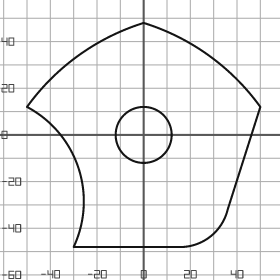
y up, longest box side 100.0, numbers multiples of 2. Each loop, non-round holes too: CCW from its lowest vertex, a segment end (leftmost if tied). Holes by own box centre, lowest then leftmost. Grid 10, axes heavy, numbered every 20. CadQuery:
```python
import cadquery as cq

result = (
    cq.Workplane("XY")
    .moveTo(-30.0, -48.0)
    .lineTo(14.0, -48.0)
    .threePointArc((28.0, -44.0), (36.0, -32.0))
    .lineTo(50.0, 12.0)
    .threePointArc((28.0, 34.0), (0.0, 48.0))
    .threePointArc((-28.0, 34.0), (-50.0, 12.0))
    .threePointArc((-28.0, -14.0), (-30.0, -48.0))
    .close()
    .moveTo(0.0, 0.0)
    .circle(12.0)
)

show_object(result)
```